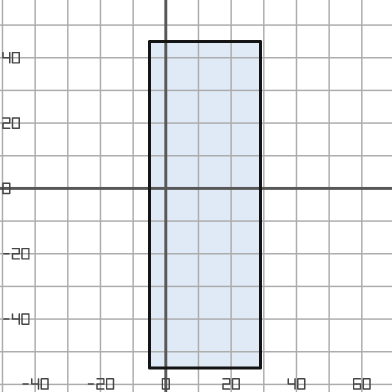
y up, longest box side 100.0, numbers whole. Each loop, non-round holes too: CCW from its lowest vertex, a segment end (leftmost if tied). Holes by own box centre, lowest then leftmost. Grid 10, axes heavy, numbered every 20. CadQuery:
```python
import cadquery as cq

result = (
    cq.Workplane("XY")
    .moveTo(-5.0, -55.0)
    .lineTo(29.0, -55.0)
    .lineTo(29.0, 45.0)
    .lineTo(-5.0, 45.0)
    .close()
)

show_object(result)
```